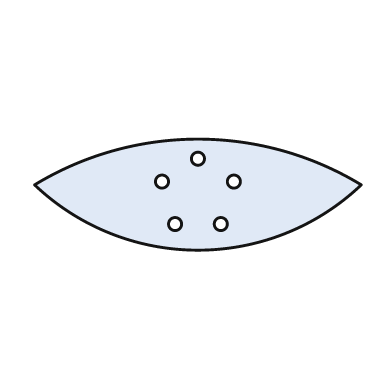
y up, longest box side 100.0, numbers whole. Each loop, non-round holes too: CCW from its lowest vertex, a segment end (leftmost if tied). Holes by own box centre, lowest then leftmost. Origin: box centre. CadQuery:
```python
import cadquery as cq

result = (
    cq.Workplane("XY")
    .moveTo(-50.0, 3.0)
    .threePointArc((0.0, -17.0), (50.0, 3.0))
    .threePointArc((0.0, 17.0), (-50.0, 3.0))
    .close()
    .moveTo(-7.0, -9.0)
    .circle(2.0)
    .moveTo(7.0, -9.0)
    .circle(2.0)
    .moveTo(-11.0, 4.0)
    .circle(2.0)
    .moveTo(11.0, 4.0)
    .circle(2.0)
    .moveTo(0.0, 11.0)
    .circle(2.0)
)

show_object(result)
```